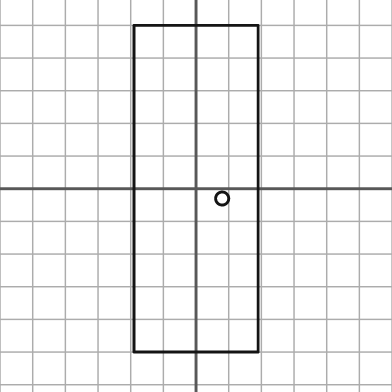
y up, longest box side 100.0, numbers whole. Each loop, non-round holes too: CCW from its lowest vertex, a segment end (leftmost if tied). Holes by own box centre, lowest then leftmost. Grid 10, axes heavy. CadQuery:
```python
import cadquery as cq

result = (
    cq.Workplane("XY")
    .moveTo(-19.0, -50.0)
    .lineTo(19.0, -50.0)
    .lineTo(19.0, 50.0)
    .lineTo(-19.0, 50.0)
    .close()
    .moveTo(8.0, -3.0)
    .circle(2.0)
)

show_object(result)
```